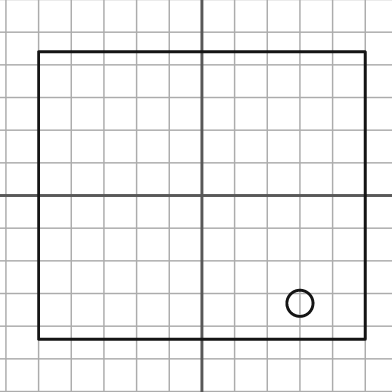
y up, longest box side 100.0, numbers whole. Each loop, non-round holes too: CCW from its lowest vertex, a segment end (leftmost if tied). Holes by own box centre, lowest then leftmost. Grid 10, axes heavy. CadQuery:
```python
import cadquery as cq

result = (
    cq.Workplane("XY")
    .moveTo(-50.0, -44.0)
    .lineTo(50.0, -44.0)
    .lineTo(50.0, 44.0)
    .lineTo(-50.0, 44.0)
    .close()
    .moveTo(30.0, -33.0)
    .circle(4.0)
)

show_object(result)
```